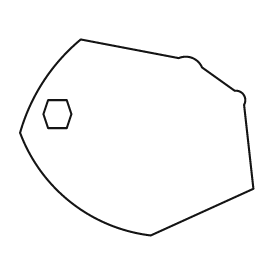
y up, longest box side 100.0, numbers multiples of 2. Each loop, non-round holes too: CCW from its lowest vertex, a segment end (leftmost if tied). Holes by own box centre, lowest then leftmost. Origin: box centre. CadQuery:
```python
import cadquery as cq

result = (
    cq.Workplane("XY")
    .moveTo(6.0, -42.0)
    .lineTo(50.0, -22.0)
    .lineTo(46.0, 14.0)
    .threePointArc((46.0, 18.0), (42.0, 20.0))
    .lineTo(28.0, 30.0)
    .threePointArc((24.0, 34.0), (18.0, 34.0))
    .lineTo(-24.0, 42.0)
    .threePointArc((-40.0, 24.0), (-50.0, 2.0))
    .threePointArc((-28.0, -28.0), (6.0, -42.0))
    .close()
    .moveTo(-38.0, 4.0)
    .lineTo(-30.0, 4.0)
    .lineTo(-28.0, 10.0)
    .lineTo(-30.0, 16.0)
    .lineTo(-38.0, 16.0)
    .lineTo(-40.0, 10.0)
    .close()
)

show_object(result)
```